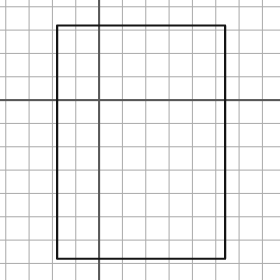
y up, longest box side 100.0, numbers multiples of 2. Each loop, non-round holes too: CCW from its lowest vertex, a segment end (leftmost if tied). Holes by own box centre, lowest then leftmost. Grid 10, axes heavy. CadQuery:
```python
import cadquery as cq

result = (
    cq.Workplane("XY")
    .moveTo(-18.0, -68.0)
    .lineTo(54.0, -68.0)
    .lineTo(54.0, 32.0)
    .lineTo(-18.0, 32.0)
    .close()
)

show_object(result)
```